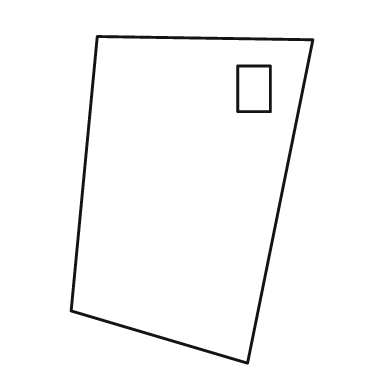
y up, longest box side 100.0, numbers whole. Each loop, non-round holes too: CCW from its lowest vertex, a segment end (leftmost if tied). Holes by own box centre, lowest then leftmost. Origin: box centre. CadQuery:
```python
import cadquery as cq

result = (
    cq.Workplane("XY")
    .moveTo(17.0, -50.0)
    .lineTo(37.0, 49.0)
    .lineTo(-29.0, 50.0)
    .lineTo(-37.0, -34.0)
    .close()
    .moveTo(14.0, 27.0)
    .lineTo(24.0, 27.0)
    .lineTo(24.0, 41.0)
    .lineTo(14.0, 41.0)
    .close()
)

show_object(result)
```